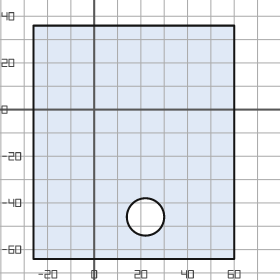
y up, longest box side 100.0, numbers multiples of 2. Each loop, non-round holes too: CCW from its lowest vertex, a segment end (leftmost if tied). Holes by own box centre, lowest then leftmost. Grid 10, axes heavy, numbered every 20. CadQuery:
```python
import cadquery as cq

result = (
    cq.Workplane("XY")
    .moveTo(-26.0, -64.0)
    .lineTo(60.0, -64.0)
    .lineTo(60.0, 36.0)
    .lineTo(-26.0, 36.0)
    .close()
    .moveTo(22.0, -46.0)
    .circle(8.0)
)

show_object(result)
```